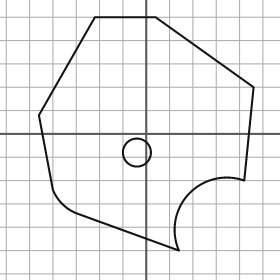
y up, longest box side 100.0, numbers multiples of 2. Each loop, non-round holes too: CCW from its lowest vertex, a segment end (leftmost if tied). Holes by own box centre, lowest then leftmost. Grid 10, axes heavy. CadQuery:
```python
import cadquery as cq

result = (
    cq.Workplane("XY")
    .moveTo(14.0, -50.0)
    .threePointArc((18.0, -26.0), (42.0, -20.0))
    .lineTo(46.0, 20.0)
    .lineTo(4.0, 50.0)
    .lineTo(-22.0, 50.0)
    .lineTo(-46.0, 8.0)
    .lineTo(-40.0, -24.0)
    .threePointArc((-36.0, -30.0), (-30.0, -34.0))
    .close()
    .moveTo(-4.0, -8.0)
    .circle(6.0)
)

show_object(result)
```